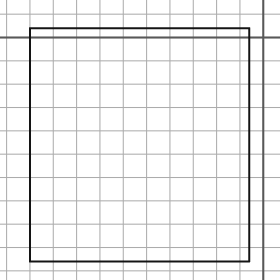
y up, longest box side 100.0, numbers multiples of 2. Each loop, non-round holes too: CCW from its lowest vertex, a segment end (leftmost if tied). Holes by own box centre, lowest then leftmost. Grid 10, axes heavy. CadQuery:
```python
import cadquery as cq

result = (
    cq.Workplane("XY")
    .moveTo(-100.0, -96.0)
    .lineTo(-6.0, -96.0)
    .lineTo(-6.0, 4.0)
    .lineTo(-100.0, 4.0)
    .close()
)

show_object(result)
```